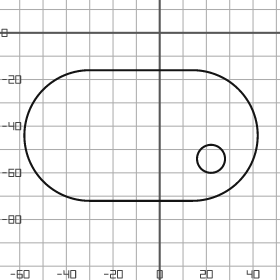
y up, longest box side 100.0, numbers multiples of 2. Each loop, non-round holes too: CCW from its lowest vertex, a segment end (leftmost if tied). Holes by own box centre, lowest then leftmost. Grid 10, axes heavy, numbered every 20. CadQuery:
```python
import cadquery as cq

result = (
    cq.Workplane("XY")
    .moveTo(-30.0, -72.0)
    .lineTo(14.0, -72.0)
    .threePointArc((42.0, -44.0), (14.0, -16.0))
    .lineTo(-30.0, -16.0)
    .threePointArc((-58.0, -44.0), (-30.0, -72.0))
    .close()
    .moveTo(22.0, -54.0)
    .circle(6.0)
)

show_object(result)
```